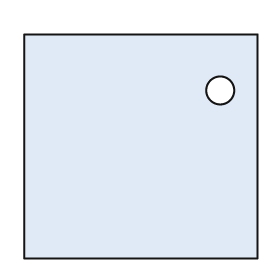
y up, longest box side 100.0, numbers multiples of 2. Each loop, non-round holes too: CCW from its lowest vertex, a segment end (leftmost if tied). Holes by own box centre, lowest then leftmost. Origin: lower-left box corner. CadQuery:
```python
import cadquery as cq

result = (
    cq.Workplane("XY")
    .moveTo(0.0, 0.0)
    .lineTo(100.0, 0.0)
    .lineTo(100.0, 96.0)
    .lineTo(0.0, 96.0)
    .close()
    .moveTo(84.0, 72.0)
    .circle(6.0)
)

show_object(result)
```